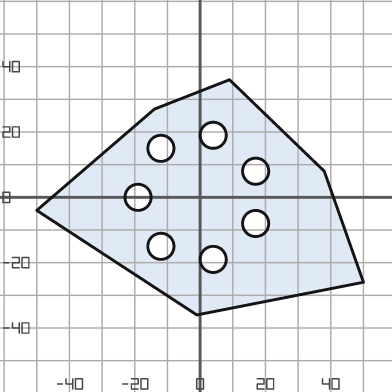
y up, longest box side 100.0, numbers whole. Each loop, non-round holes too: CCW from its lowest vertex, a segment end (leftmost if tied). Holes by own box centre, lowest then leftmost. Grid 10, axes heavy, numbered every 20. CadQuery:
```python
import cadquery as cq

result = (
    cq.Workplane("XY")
    .moveTo(-1.0, -36.0)
    .lineTo(50.0, -26.0)
    .lineTo(38.0, 8.0)
    .lineTo(9.0, 36.0)
    .lineTo(-14.0, 27.0)
    .lineTo(-50.0, -4.0)
    .close()
    .moveTo(4.0, -19.0)
    .circle(4.0)
    .moveTo(-12.0, -15.0)
    .circle(4.0)
    .moveTo(17.0, -8.0)
    .circle(4.0)
    .moveTo(-19.0, 0.0)
    .circle(4.0)
    .moveTo(17.0, 8.0)
    .circle(4.0)
    .moveTo(-12.0, 15.0)
    .circle(4.0)
    .moveTo(4.0, 19.0)
    .circle(4.0)
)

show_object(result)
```